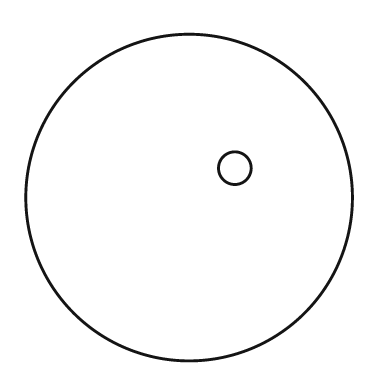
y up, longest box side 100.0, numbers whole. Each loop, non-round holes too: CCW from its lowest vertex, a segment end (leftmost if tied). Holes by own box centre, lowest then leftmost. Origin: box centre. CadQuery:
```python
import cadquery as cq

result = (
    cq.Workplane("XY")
    .moveTo(0.0, 0.0)
    .circle(50.0)
    .moveTo(14.0, 9.0)
    .circle(5.0)
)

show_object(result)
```